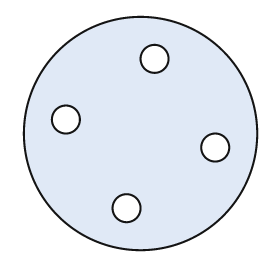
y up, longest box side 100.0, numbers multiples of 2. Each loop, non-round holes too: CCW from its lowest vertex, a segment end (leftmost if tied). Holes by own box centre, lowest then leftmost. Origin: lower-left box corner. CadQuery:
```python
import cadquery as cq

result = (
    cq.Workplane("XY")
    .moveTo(50.0, 50.0)
    .circle(50.0)
    .moveTo(44.0, 18.0)
    .circle(6.0)
    .moveTo(82.0, 44.0)
    .circle(6.0)
    .moveTo(18.0, 56.0)
    .circle(6.0)
    .moveTo(56.0, 82.0)
    .circle(6.0)
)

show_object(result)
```